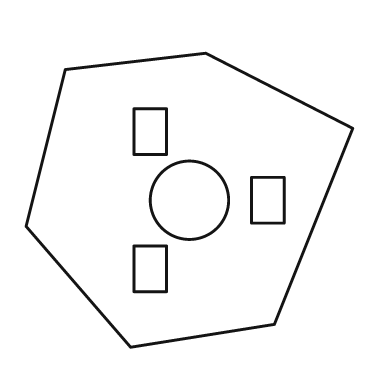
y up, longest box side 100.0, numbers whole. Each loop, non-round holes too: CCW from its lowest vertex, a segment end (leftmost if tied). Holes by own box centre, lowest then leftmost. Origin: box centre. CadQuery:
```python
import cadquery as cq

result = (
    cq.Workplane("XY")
    .moveTo(-18.0, -45.0)
    .lineTo(26.0, -38.0)
    .lineTo(50.0, 22.0)
    .lineTo(5.0, 45.0)
    .lineTo(-38.0, 40.0)
    .lineTo(-50.0, -8.0)
    .close()
    .moveTo(-17.0, -28.0)
    .lineTo(-7.0, -28.0)
    .lineTo(-7.0, -14.0)
    .lineTo(-17.0, -14.0)
    .close()
    .moveTo(0.0, 0.0)
    .circle(12.0)
    .moveTo(19.0, -7.0)
    .lineTo(29.0, -7.0)
    .lineTo(29.0, 7.0)
    .lineTo(19.0, 7.0)
    .close()
    .moveTo(-17.0, 14.0)
    .lineTo(-7.0, 14.0)
    .lineTo(-7.0, 28.0)
    .lineTo(-17.0, 28.0)
    .close()
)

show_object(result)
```